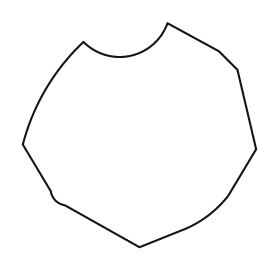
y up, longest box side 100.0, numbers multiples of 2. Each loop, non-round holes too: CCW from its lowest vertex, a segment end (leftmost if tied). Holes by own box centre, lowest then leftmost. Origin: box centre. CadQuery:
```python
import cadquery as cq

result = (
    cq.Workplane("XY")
    .moveTo(0.0, -48.0)
    .lineTo(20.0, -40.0)
    .threePointArc((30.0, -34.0), (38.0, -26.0))
    .lineTo(50.0, -6.0)
    .lineTo(42.0, 28.0)
    .lineTo(34.0, 36.0)
    .lineTo(12.0, 48.0)
    .threePointArc((-4.0, 34.0), (-24.0, 40.0))
    .threePointArc((-40.0, 20.0), (-50.0, -4.0))
    .lineTo(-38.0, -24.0)
    .threePointArc((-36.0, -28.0), (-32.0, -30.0))
    .close()
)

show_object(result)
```